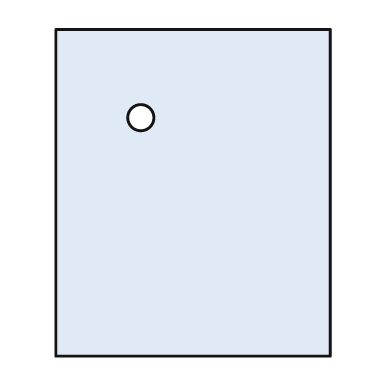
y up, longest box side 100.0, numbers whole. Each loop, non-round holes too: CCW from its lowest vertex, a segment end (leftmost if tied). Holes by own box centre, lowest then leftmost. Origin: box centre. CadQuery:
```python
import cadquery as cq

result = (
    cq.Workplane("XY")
    .moveTo(-42.0, -50.0)
    .lineTo(42.0, -50.0)
    .lineTo(42.0, 50.0)
    .lineTo(-42.0, 50.0)
    .close()
    .moveTo(-16.0, 23.0)
    .circle(4.0)
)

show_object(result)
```